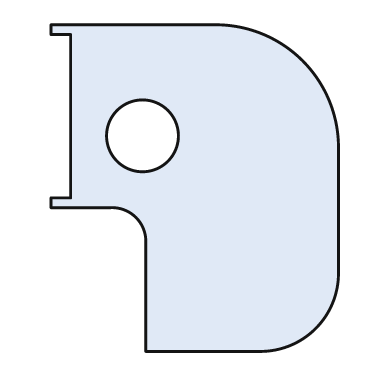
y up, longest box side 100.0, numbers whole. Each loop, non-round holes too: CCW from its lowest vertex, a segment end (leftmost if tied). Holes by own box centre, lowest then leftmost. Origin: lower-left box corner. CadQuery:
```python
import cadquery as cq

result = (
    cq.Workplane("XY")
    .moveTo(29.0, 0.0)
    .lineTo(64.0, 0.0)
    .threePointArc((81.0, 7.0), (88.0, 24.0))
    .lineTo(88.0, 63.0)
    .threePointArc((77.0, 89.0), (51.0, 100.0))
    .lineTo(0.0, 100.0)
    .lineTo(0.0, 97.0)
    .lineTo(6.0, 97.0)
    .lineTo(6.0, 47.0)
    .lineTo(0.0, 47.0)
    .lineTo(0.0, 44.0)
    .lineTo(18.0, 44.0)
    .threePointArc((26.0, 41.0), (29.0, 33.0))
    .close()
    .moveTo(28.0, 66.0)
    .circle(11.0)
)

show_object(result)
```